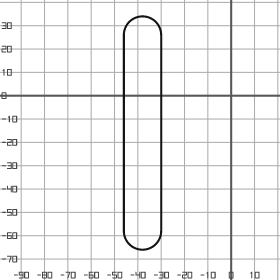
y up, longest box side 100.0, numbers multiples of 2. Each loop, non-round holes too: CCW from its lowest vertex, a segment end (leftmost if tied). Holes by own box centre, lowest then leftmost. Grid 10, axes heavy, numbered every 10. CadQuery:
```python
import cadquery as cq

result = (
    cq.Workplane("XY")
    .moveTo(-46.0, -58.0)
    .threePointArc((-38.0, -66.0), (-30.0, -58.0))
    .lineTo(-30.0, 26.0)
    .threePointArc((-38.0, 34.0), (-46.0, 26.0))
    .close()
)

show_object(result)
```